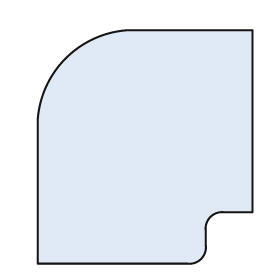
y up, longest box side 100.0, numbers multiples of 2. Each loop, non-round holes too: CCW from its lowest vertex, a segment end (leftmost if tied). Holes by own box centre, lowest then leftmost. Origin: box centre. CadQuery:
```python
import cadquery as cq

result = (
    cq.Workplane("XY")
    .moveTo(-46.0, -50.0)
    .lineTo(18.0, -50.0)
    .threePointArc((24.0, -48.0), (26.0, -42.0))
    .lineTo(26.0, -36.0)
    .threePointArc((28.0, -30.0), (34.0, -28.0))
    .lineTo(46.0, -28.0)
    .lineTo(46.0, 50.0)
    .lineTo(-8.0, 50.0)
    .threePointArc((-34.0, 38.0), (-46.0, 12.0))
    .close()
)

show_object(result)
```